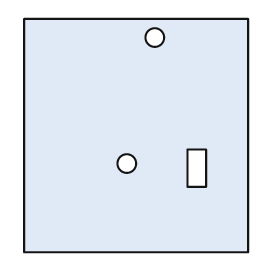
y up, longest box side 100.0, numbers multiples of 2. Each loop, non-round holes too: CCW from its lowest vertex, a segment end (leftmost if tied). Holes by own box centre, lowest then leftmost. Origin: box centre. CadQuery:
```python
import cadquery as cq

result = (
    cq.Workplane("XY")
    .moveTo(-48.0, -50.0)
    .lineTo(48.0, -50.0)
    .lineTo(48.0, 50.0)
    .lineTo(-48.0, 50.0)
    .close()
    .moveTo(22.0, -22.0)
    .lineTo(30.0, -22.0)
    .lineTo(30.0, -6.0)
    .lineTo(22.0, -6.0)
    .close()
    .moveTo(-4.0, -12.0)
    .circle(4.0)
    .moveTo(8.0, 42.0)
    .circle(4.0)
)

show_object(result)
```